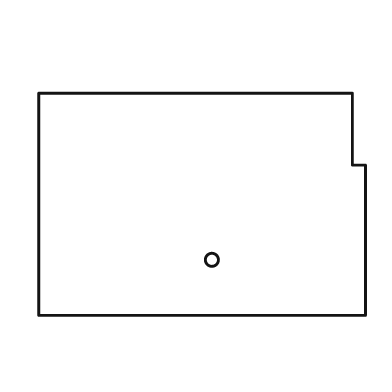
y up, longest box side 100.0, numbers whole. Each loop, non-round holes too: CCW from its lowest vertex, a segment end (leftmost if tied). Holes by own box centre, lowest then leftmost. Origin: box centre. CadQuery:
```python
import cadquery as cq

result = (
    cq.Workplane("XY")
    .moveTo(-50.0, -34.0)
    .lineTo(50.0, -34.0)
    .lineTo(50.0, 12.0)
    .lineTo(46.0, 12.0)
    .lineTo(46.0, 34.0)
    .lineTo(-50.0, 34.0)
    .close()
    .moveTo(3.0, -17.0)
    .circle(2.0)
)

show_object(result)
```